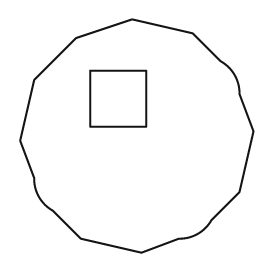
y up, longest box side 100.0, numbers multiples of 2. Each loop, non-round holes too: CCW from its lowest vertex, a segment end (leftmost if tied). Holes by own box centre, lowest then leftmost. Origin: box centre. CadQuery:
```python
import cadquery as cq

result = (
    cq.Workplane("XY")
    .moveTo(2.0, -50.0)
    .lineTo(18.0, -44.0)
    .threePointArc((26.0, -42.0), (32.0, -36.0))
    .lineTo(44.0, -24.0)
    .lineTo(50.0, 2.0)
    .lineTo(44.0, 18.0)
    .threePointArc((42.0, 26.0), (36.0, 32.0))
    .lineTo(24.0, 44.0)
    .lineTo(-2.0, 50.0)
    .lineTo(-26.0, 42.0)
    .lineTo(-44.0, 24.0)
    .lineTo(-50.0, -2.0)
    .lineTo(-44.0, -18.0)
    .threePointArc((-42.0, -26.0), (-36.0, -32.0))
    .lineTo(-24.0, -44.0)
    .close()
    .moveTo(-20.0, 4.0)
    .lineTo(4.0, 4.0)
    .lineTo(4.0, 28.0)
    .lineTo(-20.0, 28.0)
    .close()
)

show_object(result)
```